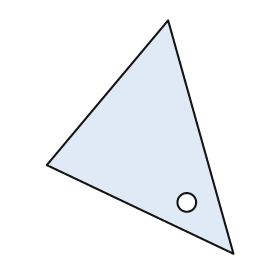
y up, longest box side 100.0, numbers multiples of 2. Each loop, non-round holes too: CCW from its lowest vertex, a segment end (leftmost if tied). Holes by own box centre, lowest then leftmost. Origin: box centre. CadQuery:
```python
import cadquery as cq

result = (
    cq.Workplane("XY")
    .moveTo(40.0, -50.0)
    .lineTo(12.0, 50.0)
    .lineTo(-40.0, -12.0)
    .close()
    .moveTo(20.0, -28.0)
    .circle(4.0)
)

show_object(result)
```